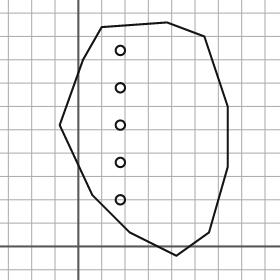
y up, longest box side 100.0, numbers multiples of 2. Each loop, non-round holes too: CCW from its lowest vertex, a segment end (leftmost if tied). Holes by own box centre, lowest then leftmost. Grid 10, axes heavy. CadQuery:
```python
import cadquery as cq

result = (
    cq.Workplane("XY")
    .moveTo(42.0, -4.0)
    .lineTo(56.0, 6.0)
    .lineTo(64.0, 34.0)
    .lineTo(64.0, 60.0)
    .lineTo(54.0, 90.0)
    .lineTo(38.0, 96.0)
    .lineTo(10.0, 94.0)
    .lineTo(2.0, 80.0)
    .lineTo(-8.0, 52.0)
    .lineTo(6.0, 22.0)
    .lineTo(22.0, 6.0)
    .close()
    .moveTo(18.0, 20.0)
    .circle(2.0)
    .moveTo(18.0, 36.0)
    .circle(2.0)
    .moveTo(18.0, 52.0)
    .circle(2.0)
    .moveTo(18.0, 68.0)
    .circle(2.0)
    .moveTo(18.0, 84.0)
    .circle(2.0)
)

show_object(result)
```